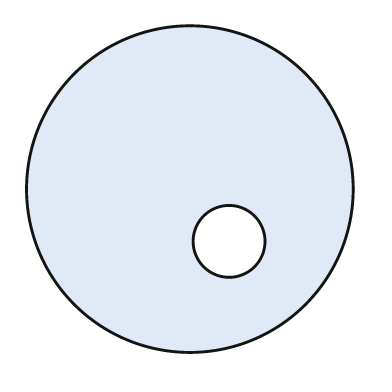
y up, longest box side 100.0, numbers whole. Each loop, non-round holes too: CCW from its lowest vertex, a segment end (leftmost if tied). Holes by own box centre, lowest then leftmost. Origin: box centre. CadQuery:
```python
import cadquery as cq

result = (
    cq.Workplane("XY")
    .moveTo(0.0, 0.0)
    .circle(50.0)
    .moveTo(12.0, -16.0)
    .circle(11.0)
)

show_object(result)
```